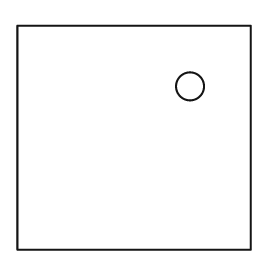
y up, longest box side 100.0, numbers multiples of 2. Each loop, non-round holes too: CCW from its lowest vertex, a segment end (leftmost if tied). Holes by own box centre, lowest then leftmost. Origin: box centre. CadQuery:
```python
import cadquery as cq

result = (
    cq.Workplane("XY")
    .moveTo(-50.0, -48.0)
    .lineTo(50.0, -48.0)
    .lineTo(50.0, 48.0)
    .lineTo(-50.0, 48.0)
    .close()
    .moveTo(24.0, 22.0)
    .circle(6.0)
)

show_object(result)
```